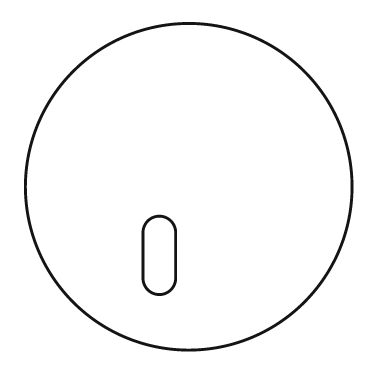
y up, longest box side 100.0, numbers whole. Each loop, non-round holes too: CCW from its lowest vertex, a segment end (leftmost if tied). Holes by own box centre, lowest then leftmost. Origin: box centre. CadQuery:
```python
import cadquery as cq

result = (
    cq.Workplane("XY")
    .moveTo(0.0, 0.0)
    .circle(50.0)
    .moveTo(-14.0, -28.0)
    .threePointArc((-9.0, -33.0), (-4.0, -28.0))
    .lineTo(-4.0, -14.0)
    .threePointArc((-9.0, -9.0), (-14.0, -14.0))
    .close()
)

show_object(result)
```